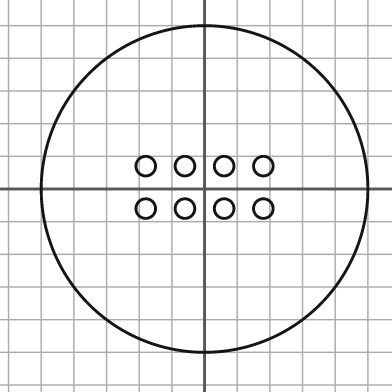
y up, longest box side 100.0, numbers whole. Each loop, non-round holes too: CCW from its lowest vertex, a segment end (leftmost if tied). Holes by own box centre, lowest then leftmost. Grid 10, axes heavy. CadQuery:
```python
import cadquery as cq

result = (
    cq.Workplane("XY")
    .moveTo(0.0, 0.0)
    .circle(50.0)
    .moveTo(-18.0, -6.0)
    .circle(3.0)
    .moveTo(-6.0, -6.0)
    .circle(3.0)
    .moveTo(6.0, -6.0)
    .circle(3.0)
    .moveTo(18.0, -6.0)
    .circle(3.0)
    .moveTo(-18.0, 7.0)
    .circle(3.0)
    .moveTo(-6.0, 7.0)
    .circle(3.0)
    .moveTo(6.0, 7.0)
    .circle(3.0)
    .moveTo(18.0, 7.0)
    .circle(3.0)
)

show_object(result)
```